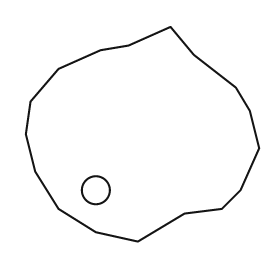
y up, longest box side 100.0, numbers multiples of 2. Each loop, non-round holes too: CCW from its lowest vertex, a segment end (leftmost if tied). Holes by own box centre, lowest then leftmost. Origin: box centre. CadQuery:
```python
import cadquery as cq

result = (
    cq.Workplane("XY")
    .moveTo(-2.0, -46.0)
    .lineTo(18.0, -34.0)
    .lineTo(34.0, -32.0)
    .lineTo(42.0, -24.0)
    .lineTo(50.0, -6.0)
    .lineTo(46.0, 10.0)
    .lineTo(40.0, 20.0)
    .lineTo(22.0, 34.0)
    .lineTo(12.0, 46.0)
    .lineTo(-6.0, 38.0)
    .lineTo(-18.0, 36.0)
    .lineTo(-36.0, 28.0)
    .lineTo(-48.0, 14.0)
    .lineTo(-50.0, 0.0)
    .lineTo(-46.0, -16.0)
    .lineTo(-36.0, -32.0)
    .lineTo(-20.0, -42.0)
    .close()
    .moveTo(-20.0, -24.0)
    .circle(6.0)
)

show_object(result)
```